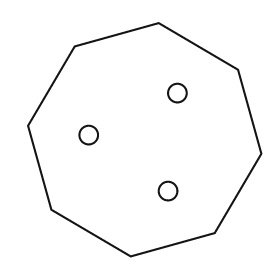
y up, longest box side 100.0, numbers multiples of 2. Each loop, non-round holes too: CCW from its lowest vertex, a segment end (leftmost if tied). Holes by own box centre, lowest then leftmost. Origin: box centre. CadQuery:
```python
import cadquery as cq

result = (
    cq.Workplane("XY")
    .moveTo(-6.0, -50.0)
    .lineTo(30.0, -40.0)
    .lineTo(50.0, -6.0)
    .lineTo(40.0, 30.0)
    .lineTo(6.0, 50.0)
    .lineTo(-30.0, 40.0)
    .lineTo(-50.0, 6.0)
    .lineTo(-40.0, -30.0)
    .close()
    .moveTo(10.0, -22.0)
    .circle(4.0)
    .moveTo(-24.0, 2.0)
    .circle(4.0)
    .moveTo(14.0, 20.0)
    .circle(4.0)
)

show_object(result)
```